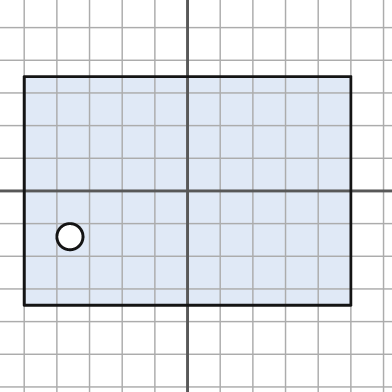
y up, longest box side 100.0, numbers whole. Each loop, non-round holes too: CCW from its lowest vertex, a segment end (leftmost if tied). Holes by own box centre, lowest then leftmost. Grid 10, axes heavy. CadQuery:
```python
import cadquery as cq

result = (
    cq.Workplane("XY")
    .moveTo(-50.0, -35.0)
    .lineTo(50.0, -35.0)
    .lineTo(50.0, 35.0)
    .lineTo(-50.0, 35.0)
    .close()
    .moveTo(-36.0, -14.0)
    .circle(4.0)
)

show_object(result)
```